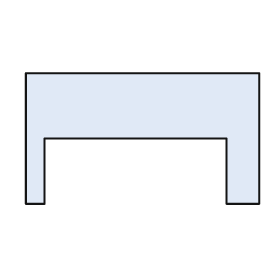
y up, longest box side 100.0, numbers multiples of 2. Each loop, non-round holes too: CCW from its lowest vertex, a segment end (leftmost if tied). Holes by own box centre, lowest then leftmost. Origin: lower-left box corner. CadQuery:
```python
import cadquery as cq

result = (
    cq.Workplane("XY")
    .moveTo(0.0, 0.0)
    .lineTo(8.0, 0.0)
    .lineTo(8.0, 28.0)
    .lineTo(86.0, 28.0)
    .lineTo(86.0, 0.0)
    .lineTo(100.0, 0.0)
    .lineTo(100.0, 56.0)
    .lineTo(0.0, 56.0)
    .close()
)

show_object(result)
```